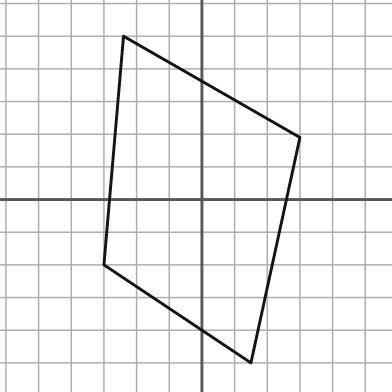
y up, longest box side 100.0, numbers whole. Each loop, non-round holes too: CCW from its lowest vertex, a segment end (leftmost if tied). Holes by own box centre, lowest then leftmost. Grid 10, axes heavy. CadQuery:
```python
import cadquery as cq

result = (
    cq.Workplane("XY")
    .moveTo(15.0, -50.0)
    .lineTo(30.0, 19.0)
    .lineTo(-24.0, 50.0)
    .lineTo(-30.0, -20.0)
    .close()
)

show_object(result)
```